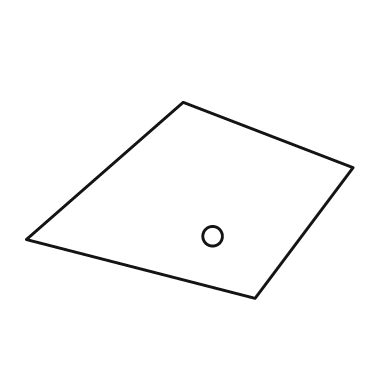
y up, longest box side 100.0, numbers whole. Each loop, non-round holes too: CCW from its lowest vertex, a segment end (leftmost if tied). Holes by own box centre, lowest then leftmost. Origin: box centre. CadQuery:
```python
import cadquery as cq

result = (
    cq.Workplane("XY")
    .moveTo(20.0, -30.0)
    .lineTo(50.0, 10.0)
    .lineTo(-2.0, 30.0)
    .lineTo(-50.0, -12.0)
    .close()
    .moveTo(7.0, -11.0)
    .circle(3.0)
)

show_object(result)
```